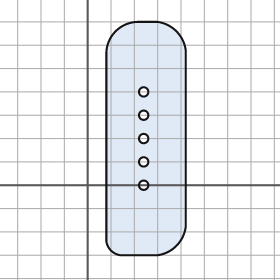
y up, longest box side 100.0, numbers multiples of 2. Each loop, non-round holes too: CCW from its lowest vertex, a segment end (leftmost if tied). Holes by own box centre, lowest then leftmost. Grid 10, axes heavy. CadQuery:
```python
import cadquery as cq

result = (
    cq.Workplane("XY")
    .moveTo(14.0, -30.0)
    .lineTo(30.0, -30.0)
    .threePointArc((38.0, -26.0), (42.0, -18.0))
    .lineTo(42.0, 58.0)
    .threePointArc((38.0, 66.0), (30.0, 70.0))
    .lineTo(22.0, 70.0)
    .threePointArc((12.0, 66.0), (8.0, 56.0))
    .lineTo(8.0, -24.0)
    .threePointArc((10.0, -28.0), (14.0, -30.0))
    .close()
    .moveTo(24.0, 0.0)
    .circle(2.0)
    .moveTo(24.0, 10.0)
    .circle(2.0)
    .moveTo(24.0, 20.0)
    .circle(2.0)
    .moveTo(24.0, 30.0)
    .circle(2.0)
    .moveTo(24.0, 40.0)
    .circle(2.0)
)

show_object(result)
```